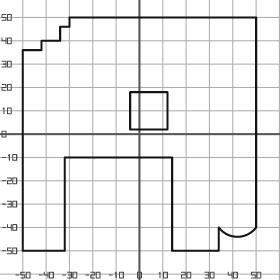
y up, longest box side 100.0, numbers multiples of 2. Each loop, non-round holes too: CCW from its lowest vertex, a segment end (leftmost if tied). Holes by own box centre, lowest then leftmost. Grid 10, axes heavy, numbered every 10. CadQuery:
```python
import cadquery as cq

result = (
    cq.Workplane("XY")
    .moveTo(-50.0, -50.0)
    .lineTo(-32.0, -50.0)
    .lineTo(-32.0, -10.0)
    .lineTo(14.0, -10.0)
    .lineTo(14.0, -50.0)
    .lineTo(34.0, -50.0)
    .lineTo(34.0, -40.0)
    .threePointArc((42.0, -44.0), (50.0, -40.0))
    .lineTo(50.0, 50.0)
    .lineTo(-30.0, 50.0)
    .lineTo(-30.0, 46.0)
    .lineTo(-34.0, 46.0)
    .lineTo(-34.0, 40.0)
    .lineTo(-42.0, 40.0)
    .lineTo(-42.0, 36.0)
    .lineTo(-50.0, 36.0)
    .close()
    .moveTo(-4.0, 2.0)
    .lineTo(12.0, 2.0)
    .lineTo(12.0, 18.0)
    .lineTo(-4.0, 18.0)
    .close()
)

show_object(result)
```